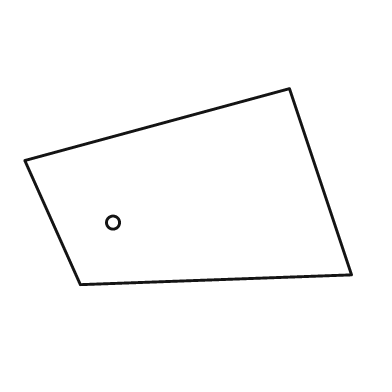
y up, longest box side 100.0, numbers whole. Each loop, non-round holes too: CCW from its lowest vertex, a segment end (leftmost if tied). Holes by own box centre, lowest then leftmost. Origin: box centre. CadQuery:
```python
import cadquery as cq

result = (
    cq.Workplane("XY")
    .moveTo(-33.0, -30.0)
    .lineTo(50.0, -27.0)
    .lineTo(31.0, 30.0)
    .lineTo(-50.0, 8.0)
    .close()
    .moveTo(-23.0, -11.0)
    .circle(2.0)
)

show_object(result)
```